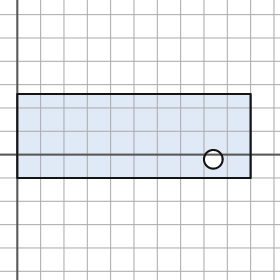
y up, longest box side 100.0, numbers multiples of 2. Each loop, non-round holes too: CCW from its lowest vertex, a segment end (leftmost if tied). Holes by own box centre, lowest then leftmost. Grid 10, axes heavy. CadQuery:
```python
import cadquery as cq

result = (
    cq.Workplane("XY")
    .moveTo(0.0, -10.0)
    .lineTo(100.0, -10.0)
    .lineTo(100.0, 26.0)
    .lineTo(0.0, 26.0)
    .close()
    .moveTo(84.0, -2.0)
    .circle(4.0)
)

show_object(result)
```